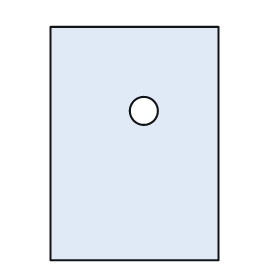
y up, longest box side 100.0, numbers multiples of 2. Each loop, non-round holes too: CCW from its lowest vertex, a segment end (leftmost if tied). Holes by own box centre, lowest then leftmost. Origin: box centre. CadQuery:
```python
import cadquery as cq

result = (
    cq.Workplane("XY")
    .moveTo(-36.0, -50.0)
    .lineTo(36.0, -50.0)
    .lineTo(36.0, 50.0)
    .lineTo(-36.0, 50.0)
    .close()
    .moveTo(4.0, 14.0)
    .circle(6.0)
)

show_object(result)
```